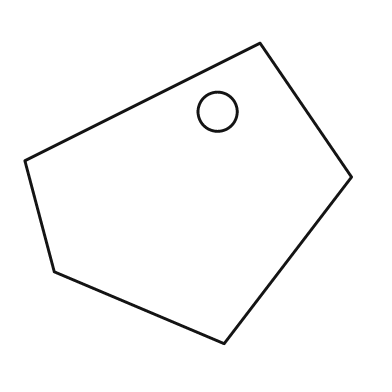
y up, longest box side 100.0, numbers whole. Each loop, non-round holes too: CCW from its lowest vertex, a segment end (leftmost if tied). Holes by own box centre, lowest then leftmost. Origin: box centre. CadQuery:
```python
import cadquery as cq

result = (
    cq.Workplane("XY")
    .moveTo(11.0, -46.0)
    .lineTo(50.0, 5.0)
    .lineTo(22.0, 46.0)
    .lineTo(-50.0, 10.0)
    .lineTo(-41.0, -24.0)
    .close()
    .moveTo(9.0, 25.0)
    .circle(6.0)
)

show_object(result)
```